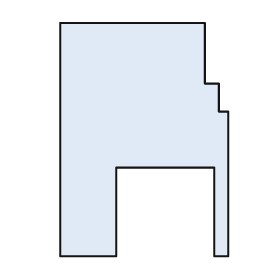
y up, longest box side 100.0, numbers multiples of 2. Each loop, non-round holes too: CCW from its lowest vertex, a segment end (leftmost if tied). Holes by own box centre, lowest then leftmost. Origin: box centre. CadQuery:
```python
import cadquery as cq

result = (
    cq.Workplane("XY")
    .moveTo(-36.0, -50.0)
    .lineTo(-12.0, -50.0)
    .lineTo(-12.0, -12.0)
    .lineTo(30.0, -12.0)
    .lineTo(30.0, -50.0)
    .lineTo(36.0, -50.0)
    .lineTo(36.0, 12.0)
    .lineTo(32.0, 12.0)
    .lineTo(32.0, 24.0)
    .lineTo(26.0, 24.0)
    .lineTo(26.0, 50.0)
    .lineTo(-36.0, 50.0)
    .close()
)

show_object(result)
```